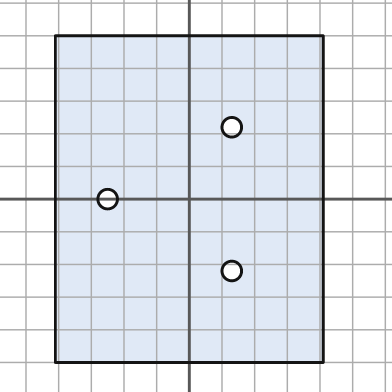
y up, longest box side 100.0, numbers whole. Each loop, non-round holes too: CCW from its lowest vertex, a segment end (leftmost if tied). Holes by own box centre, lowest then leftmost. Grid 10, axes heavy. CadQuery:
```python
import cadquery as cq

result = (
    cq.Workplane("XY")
    .moveTo(-41.0, -50.0)
    .lineTo(41.0, -50.0)
    .lineTo(41.0, 50.0)
    .lineTo(-41.0, 50.0)
    .close()
    .moveTo(13.0, -22.0)
    .circle(3.0)
    .moveTo(-25.0, 0.0)
    .circle(3.0)
    .moveTo(13.0, 22.0)
    .circle(3.0)
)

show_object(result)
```